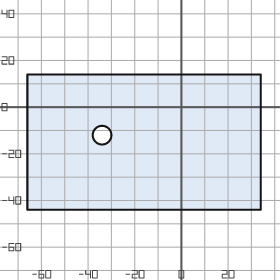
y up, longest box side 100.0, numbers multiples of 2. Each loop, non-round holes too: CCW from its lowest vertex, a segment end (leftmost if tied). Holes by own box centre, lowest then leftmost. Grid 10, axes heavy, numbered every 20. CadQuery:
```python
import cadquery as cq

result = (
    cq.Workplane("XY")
    .moveTo(-66.0, -44.0)
    .lineTo(34.0, -44.0)
    .lineTo(34.0, 14.0)
    .lineTo(-66.0, 14.0)
    .close()
    .moveTo(-34.0, -12.0)
    .circle(4.0)
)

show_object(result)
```